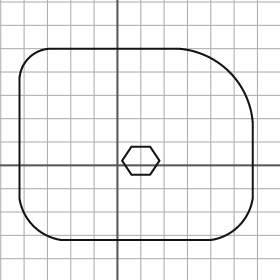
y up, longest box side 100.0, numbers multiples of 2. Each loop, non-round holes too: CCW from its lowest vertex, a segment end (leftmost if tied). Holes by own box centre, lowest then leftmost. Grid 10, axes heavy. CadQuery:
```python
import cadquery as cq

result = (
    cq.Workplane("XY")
    .moveTo(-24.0, -32.0)
    .lineTo(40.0, -32.0)
    .threePointArc((52.0, -26.0), (58.0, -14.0))
    .lineTo(58.0, 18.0)
    .threePointArc((48.0, 40.0), (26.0, 50.0))
    .lineTo(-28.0, 50.0)
    .threePointArc((-38.0, 46.0), (-42.0, 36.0))
    .lineTo(-42.0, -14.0)
    .threePointArc((-36.0, -26.0), (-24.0, -32.0))
    .close()
    .moveTo(6.0, -4.0)
    .lineTo(14.0, -4.0)
    .lineTo(18.0, 2.0)
    .lineTo(14.0, 8.0)
    .lineTo(6.0, 8.0)
    .lineTo(2.0, 2.0)
    .close()
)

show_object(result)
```